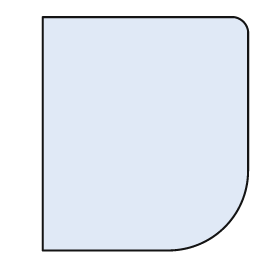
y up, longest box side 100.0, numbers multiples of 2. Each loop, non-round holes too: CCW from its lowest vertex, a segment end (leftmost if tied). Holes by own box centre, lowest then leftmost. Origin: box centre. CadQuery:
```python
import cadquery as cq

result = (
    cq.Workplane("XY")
    .moveTo(-44.0, -50.0)
    .lineTo(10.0, -50.0)
    .threePointArc((34.0, -40.0), (44.0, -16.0))
    .lineTo(44.0, 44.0)
    .threePointArc((42.0, 48.0), (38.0, 50.0))
    .lineTo(-44.0, 50.0)
    .close()
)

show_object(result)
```